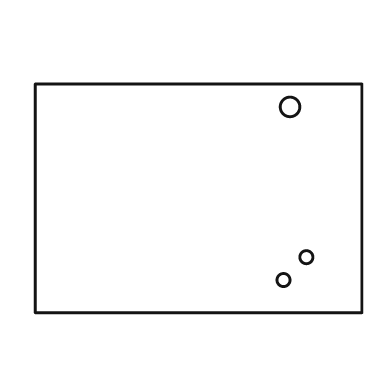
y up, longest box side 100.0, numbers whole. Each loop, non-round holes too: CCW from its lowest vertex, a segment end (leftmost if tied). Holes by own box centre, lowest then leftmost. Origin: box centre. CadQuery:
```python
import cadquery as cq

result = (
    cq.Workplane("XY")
    .moveTo(-50.0, -35.0)
    .lineTo(50.0, -35.0)
    .lineTo(50.0, 35.0)
    .lineTo(-50.0, 35.0)
    .close()
    .moveTo(26.0, -25.0)
    .circle(2.0)
    .moveTo(33.0, -18.0)
    .circle(2.0)
    .moveTo(28.0, 28.0)
    .circle(3.0)
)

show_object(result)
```